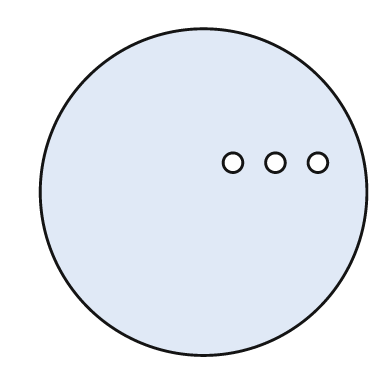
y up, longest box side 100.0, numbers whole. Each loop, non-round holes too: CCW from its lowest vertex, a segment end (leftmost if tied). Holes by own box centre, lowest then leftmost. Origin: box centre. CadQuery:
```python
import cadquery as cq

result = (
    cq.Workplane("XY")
    .moveTo(0.0, 0.0)
    .circle(50.0)
    .moveTo(9.0, 9.0)
    .circle(3.0)
    .moveTo(22.0, 9.0)
    .circle(3.0)
    .moveTo(35.0, 9.0)
    .circle(3.0)
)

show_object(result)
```